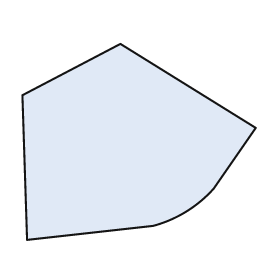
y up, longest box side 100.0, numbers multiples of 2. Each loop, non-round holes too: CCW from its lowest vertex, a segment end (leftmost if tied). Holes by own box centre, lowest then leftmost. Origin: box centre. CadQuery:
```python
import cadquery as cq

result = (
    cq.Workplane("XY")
    .moveTo(-48.0, -42.0)
    .lineTo(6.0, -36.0)
    .threePointArc((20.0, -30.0), (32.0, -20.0))
    .lineTo(50.0, 6.0)
    .lineTo(-8.0, 42.0)
    .lineTo(-50.0, 20.0)
    .close()
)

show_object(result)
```